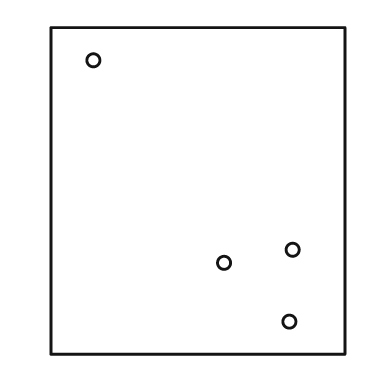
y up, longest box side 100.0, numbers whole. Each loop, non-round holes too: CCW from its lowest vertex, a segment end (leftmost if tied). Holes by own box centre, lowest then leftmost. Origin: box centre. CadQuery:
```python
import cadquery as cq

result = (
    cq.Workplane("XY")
    .moveTo(-45.0, -50.0)
    .lineTo(45.0, -50.0)
    .lineTo(45.0, 50.0)
    .lineTo(-45.0, 50.0)
    .close()
    .moveTo(28.0, -40.0)
    .circle(2.0)
    .moveTo(8.0, -22.0)
    .circle(2.0)
    .moveTo(29.0, -18.0)
    .circle(2.0)
    .moveTo(-32.0, 40.0)
    .circle(2.0)
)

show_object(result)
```